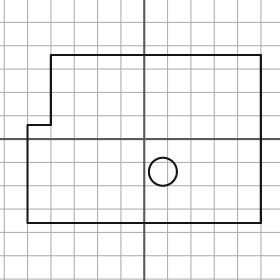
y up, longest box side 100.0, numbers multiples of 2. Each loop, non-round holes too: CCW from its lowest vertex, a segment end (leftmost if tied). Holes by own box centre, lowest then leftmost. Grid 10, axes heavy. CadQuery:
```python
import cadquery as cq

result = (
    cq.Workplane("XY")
    .moveTo(-50.0, -36.0)
    .lineTo(50.0, -36.0)
    .lineTo(50.0, 36.0)
    .lineTo(-40.0, 36.0)
    .lineTo(-40.0, 6.0)
    .lineTo(-50.0, 6.0)
    .close()
    .moveTo(8.0, -14.0)
    .circle(6.0)
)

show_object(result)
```